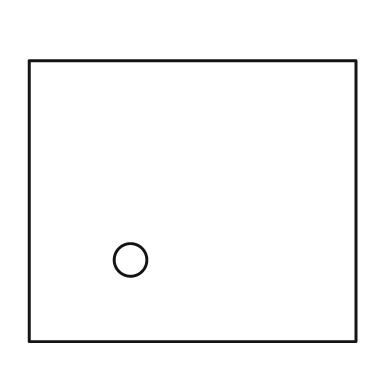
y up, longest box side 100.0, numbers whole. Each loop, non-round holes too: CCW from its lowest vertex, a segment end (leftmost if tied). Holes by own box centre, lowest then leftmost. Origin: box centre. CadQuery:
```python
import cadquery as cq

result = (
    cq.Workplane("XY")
    .moveTo(-50.0, -43.0)
    .lineTo(50.0, -43.0)
    .lineTo(50.0, 43.0)
    .lineTo(-50.0, 43.0)
    .close()
    .moveTo(-19.0, -18.0)
    .circle(5.0)
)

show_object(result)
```